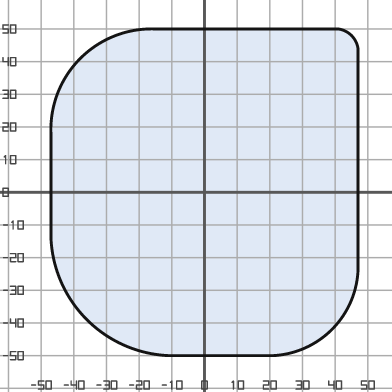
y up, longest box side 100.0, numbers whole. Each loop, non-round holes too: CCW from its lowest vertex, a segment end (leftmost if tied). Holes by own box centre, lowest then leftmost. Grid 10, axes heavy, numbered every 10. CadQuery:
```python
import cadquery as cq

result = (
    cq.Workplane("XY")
    .moveTo(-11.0, -50.0)
    .lineTo(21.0, -50.0)
    .threePointArc((39.0, -42.0), (47.0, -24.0))
    .lineTo(47.0, 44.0)
    .threePointArc((45.0, 48.0), (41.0, 50.0))
    .lineTo(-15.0, 50.0)
    .threePointArc((-38.0, 41.0), (-47.0, 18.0))
    .lineTo(-47.0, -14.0)
    .threePointArc((-36.0, -39.0), (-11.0, -50.0))
    .close()
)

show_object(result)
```